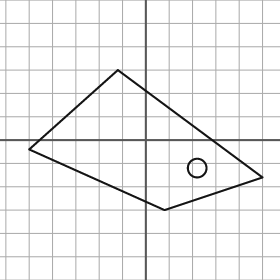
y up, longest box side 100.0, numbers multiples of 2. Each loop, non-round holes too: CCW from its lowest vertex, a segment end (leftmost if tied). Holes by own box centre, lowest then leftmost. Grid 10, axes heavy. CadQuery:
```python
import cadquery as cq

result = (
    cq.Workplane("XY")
    .moveTo(8.0, -30.0)
    .lineTo(50.0, -16.0)
    .lineTo(-12.0, 30.0)
    .lineTo(-50.0, -4.0)
    .close()
    .moveTo(22.0, -12.0)
    .circle(4.0)
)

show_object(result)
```